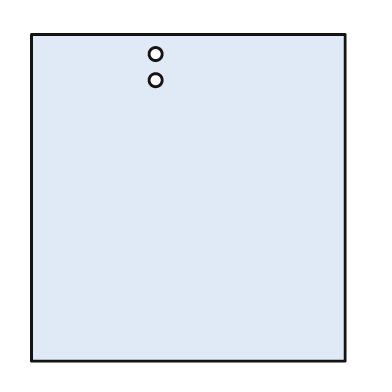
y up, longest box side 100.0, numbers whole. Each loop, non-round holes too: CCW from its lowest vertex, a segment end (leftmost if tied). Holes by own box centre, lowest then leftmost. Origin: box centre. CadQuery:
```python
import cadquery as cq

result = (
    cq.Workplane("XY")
    .moveTo(-48.0, -50.0)
    .lineTo(48.0, -50.0)
    .lineTo(48.0, 50.0)
    .lineTo(-48.0, 50.0)
    .close()
    .moveTo(-10.0, 36.0)
    .circle(2.0)
    .moveTo(-10.0, 44.0)
    .circle(2.0)
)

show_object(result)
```